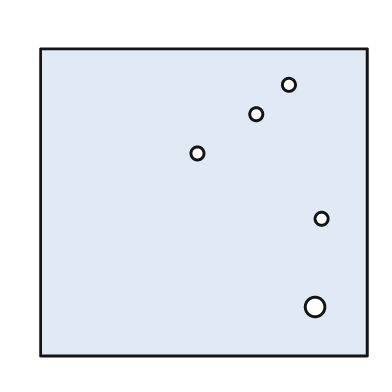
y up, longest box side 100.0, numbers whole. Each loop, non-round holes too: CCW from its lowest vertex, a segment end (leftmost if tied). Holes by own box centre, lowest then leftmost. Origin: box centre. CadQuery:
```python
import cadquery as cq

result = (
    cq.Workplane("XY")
    .moveTo(-50.0, -47.0)
    .lineTo(50.0, -47.0)
    .lineTo(50.0, 47.0)
    .lineTo(-50.0, 47.0)
    .close()
    .moveTo(34.0, -32.0)
    .circle(3.0)
    .moveTo(36.0, -5.0)
    .circle(2.0)
    .moveTo(-2.0, 15.0)
    .circle(2.0)
    .moveTo(16.0, 27.0)
    .circle(2.0)
    .moveTo(26.0, 36.0)
    .circle(2.0)
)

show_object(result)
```